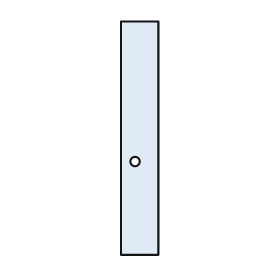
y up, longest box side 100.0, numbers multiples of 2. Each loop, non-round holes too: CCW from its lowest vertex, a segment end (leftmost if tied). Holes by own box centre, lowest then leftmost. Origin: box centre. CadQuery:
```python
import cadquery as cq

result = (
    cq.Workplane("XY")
    .moveTo(-8.0, -50.0)
    .lineTo(8.0, -50.0)
    .lineTo(8.0, 50.0)
    .lineTo(-8.0, 50.0)
    .close()
    .moveTo(-2.0, -10.0)
    .circle(2.0)
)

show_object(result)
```